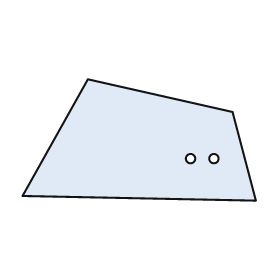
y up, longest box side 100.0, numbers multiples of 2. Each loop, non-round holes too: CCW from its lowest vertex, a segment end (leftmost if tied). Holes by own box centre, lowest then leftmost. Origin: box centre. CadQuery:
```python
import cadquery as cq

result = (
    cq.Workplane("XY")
    .moveTo(50.0, -26.0)
    .lineTo(40.0, 12.0)
    .lineTo(-22.0, 26.0)
    .lineTo(-50.0, -24.0)
    .close()
    .moveTo(22.0, -8.0)
    .circle(2.0)
    .moveTo(32.0, -8.0)
    .circle(2.0)
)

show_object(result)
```